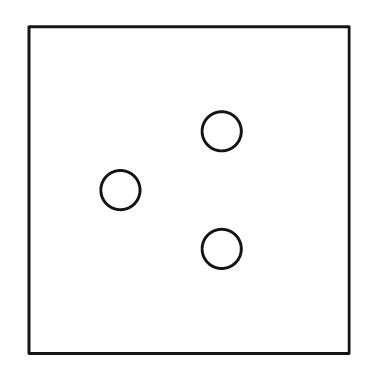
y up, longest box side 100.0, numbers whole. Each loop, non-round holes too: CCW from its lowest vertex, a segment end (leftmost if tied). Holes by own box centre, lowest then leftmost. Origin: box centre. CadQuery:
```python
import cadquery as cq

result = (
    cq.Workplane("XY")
    .moveTo(-49.0, -50.0)
    .lineTo(49.0, -50.0)
    .lineTo(49.0, 50.0)
    .lineTo(-49.0, 50.0)
    .close()
    .moveTo(10.0, -18.0)
    .circle(6.0)
    .moveTo(-21.0, 0.0)
    .circle(6.0)
    .moveTo(10.0, 18.0)
    .circle(6.0)
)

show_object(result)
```